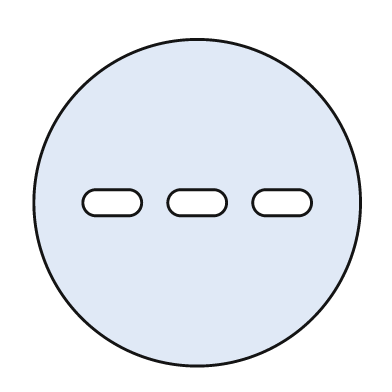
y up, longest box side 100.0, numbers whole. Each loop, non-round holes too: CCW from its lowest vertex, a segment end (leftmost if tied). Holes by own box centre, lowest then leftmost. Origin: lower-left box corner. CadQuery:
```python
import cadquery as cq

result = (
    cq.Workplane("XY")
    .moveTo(50.0, 50.0)
    .circle(50.0)
    .moveTo(19.0, 46.0)
    .lineTo(29.0, 46.0)
    .threePointArc((33.0, 50.0), (29.0, 54.0))
    .lineTo(19.0, 54.0)
    .threePointArc((15.0, 50.0), (19.0, 46.0))
    .close()
    .moveTo(45.0, 46.0)
    .lineTo(55.0, 46.0)
    .threePointArc((59.0, 50.0), (55.0, 54.0))
    .lineTo(45.0, 54.0)
    .threePointArc((41.0, 50.0), (45.0, 46.0))
    .close()
    .moveTo(71.0, 46.0)
    .lineTo(81.0, 46.0)
    .threePointArc((85.0, 50.0), (81.0, 54.0))
    .lineTo(71.0, 54.0)
    .threePointArc((67.0, 50.0), (71.0, 46.0))
    .close()
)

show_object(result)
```